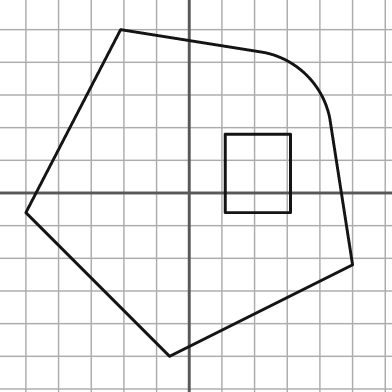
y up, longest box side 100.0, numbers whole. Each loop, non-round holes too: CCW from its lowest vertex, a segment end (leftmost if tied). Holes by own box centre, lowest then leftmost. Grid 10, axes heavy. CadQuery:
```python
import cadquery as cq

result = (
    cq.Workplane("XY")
    .moveTo(-6.0, -50.0)
    .lineTo(50.0, -22.0)
    .lineTo(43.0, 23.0)
    .threePointArc((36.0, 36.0), (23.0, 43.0))
    .lineTo(-21.0, 50.0)
    .lineTo(-50.0, -6.0)
    .close()
    .moveTo(11.0, -6.0)
    .lineTo(31.0, -6.0)
    .lineTo(31.0, 18.0)
    .lineTo(11.0, 18.0)
    .close()
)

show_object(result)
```